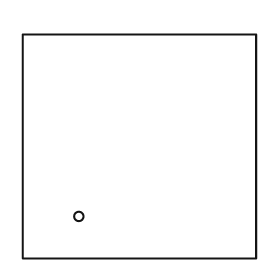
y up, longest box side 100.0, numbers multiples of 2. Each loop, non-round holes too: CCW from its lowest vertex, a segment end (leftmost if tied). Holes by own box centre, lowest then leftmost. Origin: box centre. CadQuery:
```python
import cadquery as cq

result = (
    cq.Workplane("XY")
    .moveTo(-50.0, -48.0)
    .lineTo(50.0, -48.0)
    .lineTo(50.0, 48.0)
    .lineTo(-50.0, 48.0)
    .close()
    .moveTo(-26.0, -30.0)
    .circle(2.0)
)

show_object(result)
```